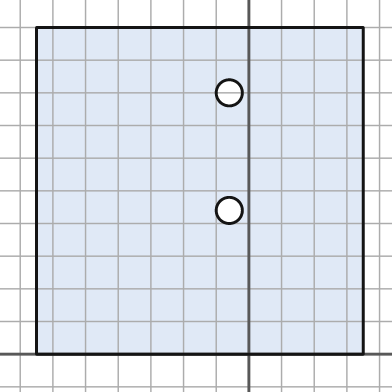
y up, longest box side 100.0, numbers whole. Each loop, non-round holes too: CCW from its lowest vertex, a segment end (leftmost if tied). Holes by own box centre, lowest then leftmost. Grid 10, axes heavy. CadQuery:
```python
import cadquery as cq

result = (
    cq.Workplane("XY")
    .moveTo(-65.0, 0.0)
    .lineTo(35.0, 0.0)
    .lineTo(35.0, 100.0)
    .lineTo(-65.0, 100.0)
    .close()
    .moveTo(-6.0, 44.0)
    .circle(4.0)
    .moveTo(-6.0, 80.0)
    .circle(4.0)
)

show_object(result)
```